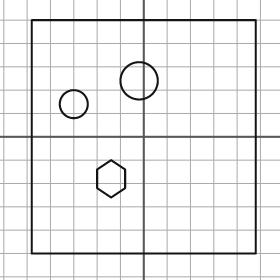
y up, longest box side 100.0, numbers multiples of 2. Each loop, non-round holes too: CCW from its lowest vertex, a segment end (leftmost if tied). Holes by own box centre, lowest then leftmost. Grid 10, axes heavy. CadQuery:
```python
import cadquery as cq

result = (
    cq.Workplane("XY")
    .moveTo(-48.0, -50.0)
    .lineTo(48.0, -50.0)
    .lineTo(48.0, 50.0)
    .lineTo(-48.0, 50.0)
    .close()
    .moveTo(-14.0, -26.0)
    .lineTo(-8.0, -22.0)
    .lineTo(-8.0, -14.0)
    .lineTo(-14.0, -10.0)
    .lineTo(-20.0, -14.0)
    .lineTo(-20.0, -22.0)
    .close()
    .moveTo(-30.0, 14.0)
    .circle(6.0)
    .moveTo(-2.0, 24.0)
    .circle(8.0)
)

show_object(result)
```